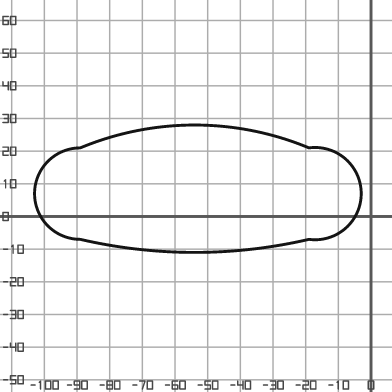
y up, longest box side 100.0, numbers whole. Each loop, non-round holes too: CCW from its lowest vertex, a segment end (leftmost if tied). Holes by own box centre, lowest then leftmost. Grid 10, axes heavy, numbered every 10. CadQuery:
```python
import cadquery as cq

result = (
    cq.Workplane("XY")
    .moveTo(-89.0, -7.0)
    .threePointArc((-54.0, -11.0), (-19.0, -7.0))
    .threePointArc((-3.0, 7.0), (-19.0, 21.0))
    .threePointArc((-54.0, 28.0), (-89.0, 21.0))
    .threePointArc((-103.0, 7.0), (-89.0, -7.0))
    .close()
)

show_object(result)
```